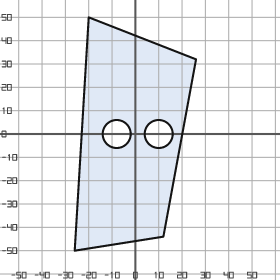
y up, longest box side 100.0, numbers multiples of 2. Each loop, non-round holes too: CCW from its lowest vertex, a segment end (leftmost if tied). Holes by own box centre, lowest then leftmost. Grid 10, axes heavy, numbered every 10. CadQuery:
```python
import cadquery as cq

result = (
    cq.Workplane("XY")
    .moveTo(-26.0, -50.0)
    .lineTo(12.0, -44.0)
    .lineTo(26.0, 32.0)
    .lineTo(-20.0, 50.0)
    .close()
    .moveTo(-8.0, 0.0)
    .circle(6.0)
    .moveTo(10.0, 0.0)
    .circle(6.0)
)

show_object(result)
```